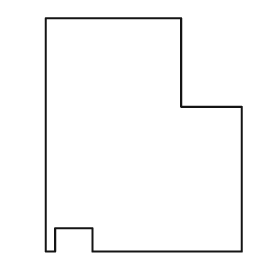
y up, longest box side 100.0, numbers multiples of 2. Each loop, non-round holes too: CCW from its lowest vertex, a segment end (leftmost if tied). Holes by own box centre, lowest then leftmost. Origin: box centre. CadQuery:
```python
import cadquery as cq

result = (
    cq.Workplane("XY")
    .moveTo(-42.0, -50.0)
    .lineTo(-38.0, -50.0)
    .lineTo(-38.0, -40.0)
    .lineTo(-22.0, -40.0)
    .lineTo(-22.0, -50.0)
    .lineTo(42.0, -50.0)
    .lineTo(42.0, 12.0)
    .lineTo(16.0, 12.0)
    .lineTo(16.0, 50.0)
    .lineTo(-42.0, 50.0)
    .close()
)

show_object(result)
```